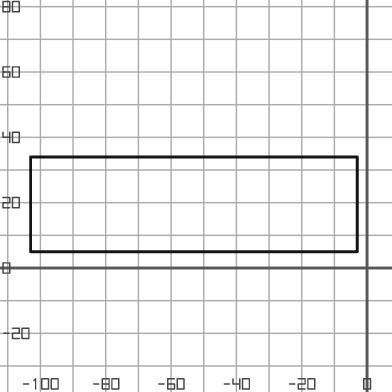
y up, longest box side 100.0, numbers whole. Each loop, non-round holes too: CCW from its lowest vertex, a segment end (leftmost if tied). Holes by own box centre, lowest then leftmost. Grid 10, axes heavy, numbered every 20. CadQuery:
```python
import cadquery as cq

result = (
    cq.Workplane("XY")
    .moveTo(-103.0, 5.0)
    .lineTo(-3.0, 5.0)
    .lineTo(-3.0, 34.0)
    .lineTo(-103.0, 34.0)
    .close()
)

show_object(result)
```